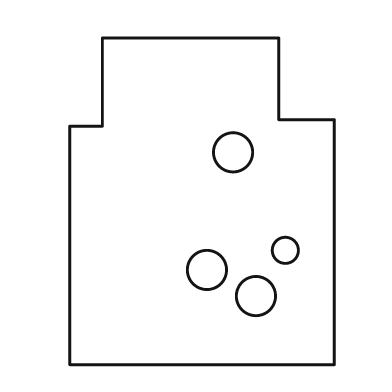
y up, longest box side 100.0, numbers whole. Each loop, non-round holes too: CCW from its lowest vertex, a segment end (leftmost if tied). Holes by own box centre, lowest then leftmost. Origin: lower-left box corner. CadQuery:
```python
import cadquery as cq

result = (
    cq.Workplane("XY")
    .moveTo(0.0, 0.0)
    .lineTo(81.0, 0.0)
    .lineTo(81.0, 75.0)
    .lineTo(64.0, 75.0)
    .lineTo(64.0, 100.0)
    .lineTo(10.0, 100.0)
    .lineTo(10.0, 73.0)
    .lineTo(0.0, 73.0)
    .close()
    .moveTo(57.0, 21.0)
    .circle(6.0)
    .moveTo(42.0, 29.0)
    .circle(6.0)
    .moveTo(66.0, 35.0)
    .circle(4.0)
    .moveTo(50.0, 65.0)
    .circle(6.0)
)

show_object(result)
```